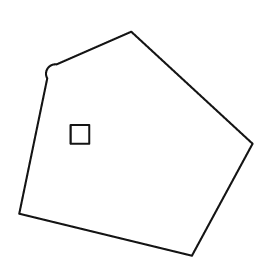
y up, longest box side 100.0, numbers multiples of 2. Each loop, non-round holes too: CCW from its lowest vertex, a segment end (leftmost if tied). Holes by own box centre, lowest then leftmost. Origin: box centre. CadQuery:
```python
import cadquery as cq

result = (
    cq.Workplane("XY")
    .moveTo(24.0, -48.0)
    .lineTo(50.0, 0.0)
    .lineTo(-2.0, 48.0)
    .lineTo(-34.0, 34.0)
    .threePointArc((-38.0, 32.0), (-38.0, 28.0))
    .lineTo(-50.0, -30.0)
    .close()
    .moveTo(-28.0, 0.0)
    .lineTo(-20.0, 0.0)
    .lineTo(-20.0, 8.0)
    .lineTo(-28.0, 8.0)
    .close()
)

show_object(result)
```